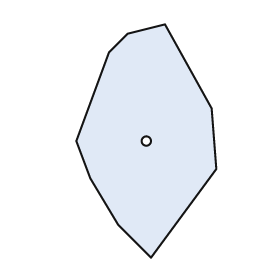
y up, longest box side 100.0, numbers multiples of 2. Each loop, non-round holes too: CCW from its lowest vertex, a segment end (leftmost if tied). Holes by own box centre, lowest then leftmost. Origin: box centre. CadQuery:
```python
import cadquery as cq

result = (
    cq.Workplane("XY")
    .moveTo(2.0, -50.0)
    .lineTo(30.0, -12.0)
    .lineTo(28.0, 14.0)
    .lineTo(8.0, 50.0)
    .lineTo(-8.0, 46.0)
    .lineTo(-16.0, 38.0)
    .lineTo(-30.0, 0.0)
    .lineTo(-24.0, -16.0)
    .lineTo(-12.0, -36.0)
    .close()
    .moveTo(0.0, 0.0)
    .circle(2.0)
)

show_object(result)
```